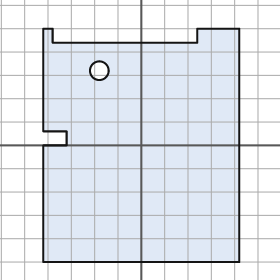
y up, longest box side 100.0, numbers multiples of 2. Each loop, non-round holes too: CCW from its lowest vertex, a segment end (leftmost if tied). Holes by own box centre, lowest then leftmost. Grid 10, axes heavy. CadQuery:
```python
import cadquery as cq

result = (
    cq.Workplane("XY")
    .moveTo(-42.0, -50.0)
    .lineTo(42.0, -50.0)
    .lineTo(42.0, 50.0)
    .lineTo(24.0, 50.0)
    .lineTo(24.0, 44.0)
    .lineTo(-38.0, 44.0)
    .lineTo(-38.0, 50.0)
    .lineTo(-42.0, 50.0)
    .lineTo(-42.0, 6.0)
    .lineTo(-32.0, 6.0)
    .lineTo(-32.0, 0.0)
    .lineTo(-42.0, 0.0)
    .close()
    .moveTo(-18.0, 32.0)
    .circle(4.0)
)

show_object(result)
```